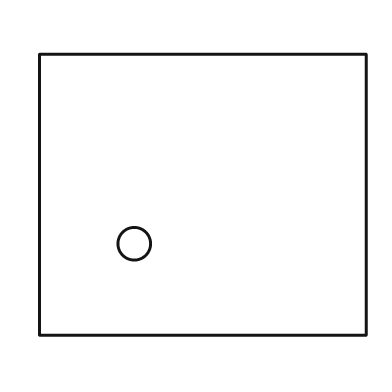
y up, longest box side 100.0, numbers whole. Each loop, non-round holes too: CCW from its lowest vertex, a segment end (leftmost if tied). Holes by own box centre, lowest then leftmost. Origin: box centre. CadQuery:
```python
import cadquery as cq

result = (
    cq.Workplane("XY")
    .moveTo(-50.0, -43.0)
    .lineTo(50.0, -43.0)
    .lineTo(50.0, 43.0)
    .lineTo(-50.0, 43.0)
    .close()
    .moveTo(-21.0, -15.0)
    .circle(5.0)
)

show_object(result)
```